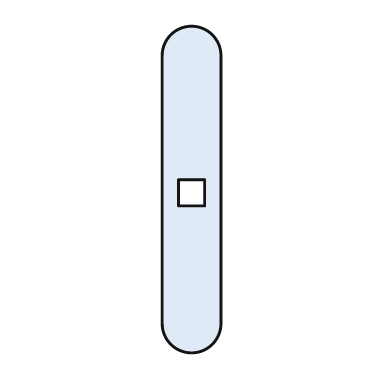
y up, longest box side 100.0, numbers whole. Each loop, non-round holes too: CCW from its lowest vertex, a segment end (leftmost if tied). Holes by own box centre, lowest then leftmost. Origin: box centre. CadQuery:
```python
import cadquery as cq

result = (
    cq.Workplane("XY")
    .moveTo(-9.0, -41.0)
    .threePointArc((0.0, -50.0), (9.0, -41.0))
    .lineTo(9.0, 41.0)
    .threePointArc((0.0, 50.0), (-9.0, 41.0))
    .close()
    .moveTo(-4.0, -5.0)
    .lineTo(4.0, -5.0)
    .lineTo(4.0, 3.0)
    .lineTo(-4.0, 3.0)
    .close()
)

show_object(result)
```